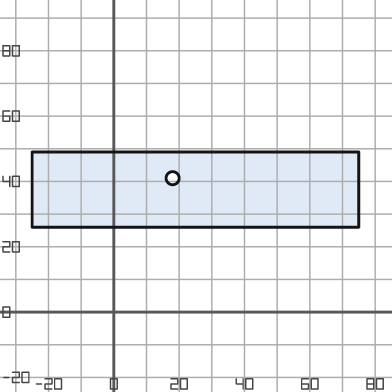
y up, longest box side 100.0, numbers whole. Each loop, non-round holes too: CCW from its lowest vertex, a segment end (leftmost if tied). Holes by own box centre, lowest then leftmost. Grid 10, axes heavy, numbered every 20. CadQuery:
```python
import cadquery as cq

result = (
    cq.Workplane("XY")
    .moveTo(-25.0, 26.0)
    .lineTo(75.0, 26.0)
    .lineTo(75.0, 49.0)
    .lineTo(-25.0, 49.0)
    .close()
    .moveTo(18.0, 41.0)
    .circle(2.0)
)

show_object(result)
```